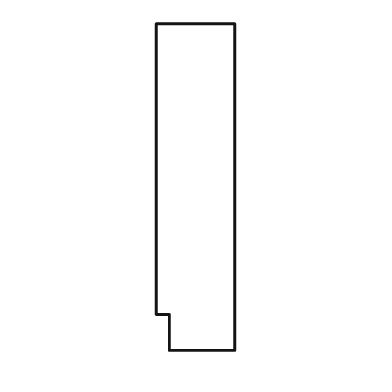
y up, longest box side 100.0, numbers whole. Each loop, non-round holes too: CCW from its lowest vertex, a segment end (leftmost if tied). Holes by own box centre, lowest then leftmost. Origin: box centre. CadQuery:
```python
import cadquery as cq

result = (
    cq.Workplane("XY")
    .moveTo(-8.0, -50.0)
    .lineTo(12.0, -50.0)
    .lineTo(12.0, 50.0)
    .lineTo(-12.0, 50.0)
    .lineTo(-12.0, -39.0)
    .lineTo(-8.0, -39.0)
    .close()
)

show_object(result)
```